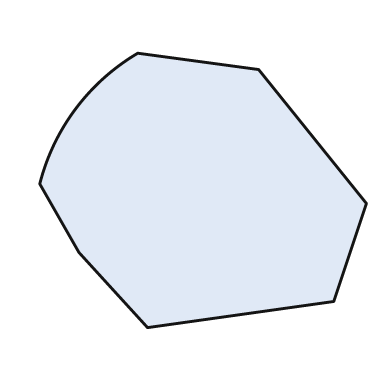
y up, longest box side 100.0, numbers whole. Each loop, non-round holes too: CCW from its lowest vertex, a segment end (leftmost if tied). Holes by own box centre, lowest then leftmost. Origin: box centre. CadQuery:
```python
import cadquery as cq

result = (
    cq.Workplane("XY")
    .moveTo(-17.0, -42.0)
    .lineTo(40.0, -34.0)
    .lineTo(50.0, -4.0)
    .lineTo(17.0, 37.0)
    .lineTo(-20.0, 42.0)
    .threePointArc((-39.0, 25.0), (-50.0, 2.0))
    .lineTo(-38.0, -19.0)
    .close()
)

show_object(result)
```